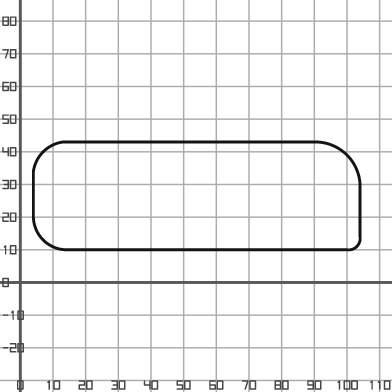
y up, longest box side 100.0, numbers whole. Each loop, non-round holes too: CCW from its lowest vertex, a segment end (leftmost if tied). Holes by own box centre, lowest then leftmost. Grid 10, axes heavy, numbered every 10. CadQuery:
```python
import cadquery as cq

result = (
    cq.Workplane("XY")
    .moveTo(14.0, 10.0)
    .lineTo(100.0, 10.0)
    .threePointArc((103.0, 11.0), (104.0, 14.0))
    .lineTo(104.0, 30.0)
    .threePointArc((100.0, 39.0), (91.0, 43.0))
    .lineTo(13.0, 43.0)
    .threePointArc((7.0, 40.0), (4.0, 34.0))
    .lineTo(4.0, 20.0)
    .threePointArc((7.0, 13.0), (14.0, 10.0))
    .close()
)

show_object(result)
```